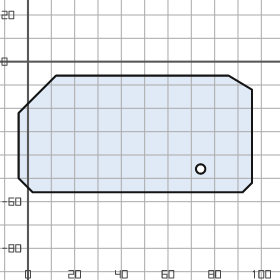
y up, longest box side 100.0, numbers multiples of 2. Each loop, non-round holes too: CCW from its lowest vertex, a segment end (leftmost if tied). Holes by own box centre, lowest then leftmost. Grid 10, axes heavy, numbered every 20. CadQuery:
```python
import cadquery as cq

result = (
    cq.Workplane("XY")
    .moveTo(2.0, -56.0)
    .lineTo(92.0, -56.0)
    .lineTo(96.0, -52.0)
    .lineTo(96.0, -12.0)
    .lineTo(86.0, -6.0)
    .lineTo(12.0, -6.0)
    .lineTo(-4.0, -22.0)
    .lineTo(-4.0, -50.0)
    .close()
    .moveTo(74.0, -46.0)
    .circle(2.0)
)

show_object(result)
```